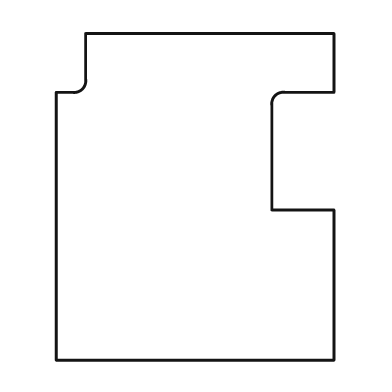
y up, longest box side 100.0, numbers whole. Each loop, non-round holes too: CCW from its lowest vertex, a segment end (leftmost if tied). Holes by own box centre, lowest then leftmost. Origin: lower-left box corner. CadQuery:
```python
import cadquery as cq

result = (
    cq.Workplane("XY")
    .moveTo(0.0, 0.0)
    .lineTo(85.0, 0.0)
    .lineTo(85.0, 46.0)
    .lineTo(66.0, 46.0)
    .lineTo(66.0, 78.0)
    .threePointArc((67.0, 81.0), (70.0, 82.0))
    .lineTo(85.0, 82.0)
    .lineTo(85.0, 100.0)
    .lineTo(9.0, 100.0)
    .lineTo(9.0, 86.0)
    .threePointArc((8.0, 83.0), (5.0, 82.0))
    .lineTo(0.0, 82.0)
    .close()
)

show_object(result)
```